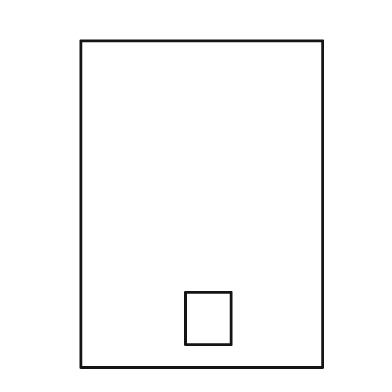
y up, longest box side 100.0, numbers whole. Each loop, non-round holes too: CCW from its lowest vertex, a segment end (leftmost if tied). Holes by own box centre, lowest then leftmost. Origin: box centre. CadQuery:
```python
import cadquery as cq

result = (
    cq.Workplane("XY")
    .moveTo(-37.0, -50.0)
    .lineTo(37.0, -50.0)
    .lineTo(37.0, 50.0)
    .lineTo(-37.0, 50.0)
    .close()
    .moveTo(-5.0, -43.0)
    .lineTo(9.0, -43.0)
    .lineTo(9.0, -27.0)
    .lineTo(-5.0, -27.0)
    .close()
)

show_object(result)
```